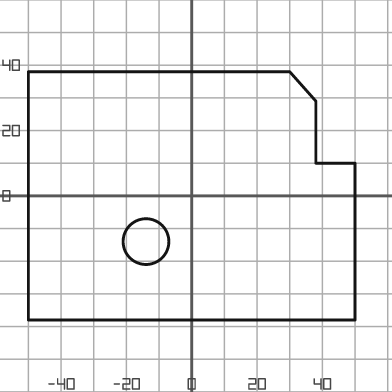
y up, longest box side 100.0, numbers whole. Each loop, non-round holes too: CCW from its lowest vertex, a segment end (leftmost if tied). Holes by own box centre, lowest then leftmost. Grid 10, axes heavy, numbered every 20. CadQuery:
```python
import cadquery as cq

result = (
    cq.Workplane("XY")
    .moveTo(-50.0, -38.0)
    .lineTo(50.0, -38.0)
    .lineTo(50.0, 10.0)
    .lineTo(38.0, 10.0)
    .lineTo(38.0, 29.0)
    .lineTo(30.0, 38.0)
    .lineTo(-50.0, 38.0)
    .close()
    .moveTo(-14.0, -14.0)
    .circle(7.0)
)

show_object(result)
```